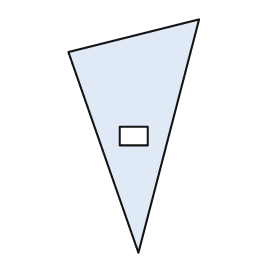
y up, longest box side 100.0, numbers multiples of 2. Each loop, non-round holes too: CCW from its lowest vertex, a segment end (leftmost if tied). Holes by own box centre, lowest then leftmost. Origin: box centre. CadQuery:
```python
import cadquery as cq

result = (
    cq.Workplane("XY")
    .moveTo(2.0, -50.0)
    .lineTo(28.0, 50.0)
    .lineTo(-28.0, 36.0)
    .close()
    .moveTo(-6.0, -4.0)
    .lineTo(6.0, -4.0)
    .lineTo(6.0, 4.0)
    .lineTo(-6.0, 4.0)
    .close()
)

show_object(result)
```